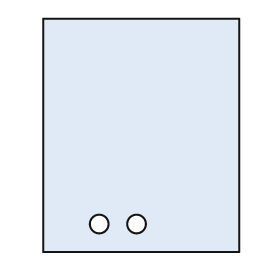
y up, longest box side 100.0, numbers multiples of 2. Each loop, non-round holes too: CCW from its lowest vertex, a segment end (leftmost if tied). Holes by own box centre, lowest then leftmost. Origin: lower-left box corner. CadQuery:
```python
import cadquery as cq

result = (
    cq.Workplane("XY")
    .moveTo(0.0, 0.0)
    .lineTo(84.0, 0.0)
    .lineTo(84.0, 100.0)
    .lineTo(0.0, 100.0)
    .close()
    .moveTo(24.0, 12.0)
    .circle(4.0)
    .moveTo(40.0, 12.0)
    .circle(4.0)
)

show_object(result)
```